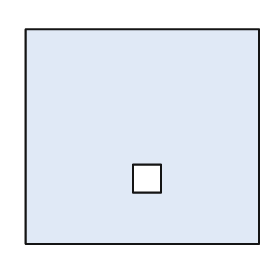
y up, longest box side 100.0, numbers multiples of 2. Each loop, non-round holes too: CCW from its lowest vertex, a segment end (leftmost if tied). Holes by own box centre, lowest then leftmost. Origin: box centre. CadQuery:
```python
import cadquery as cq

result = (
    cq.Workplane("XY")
    .moveTo(-50.0, -46.0)
    .lineTo(50.0, -46.0)
    .lineTo(50.0, 46.0)
    .lineTo(-50.0, 46.0)
    .close()
    .moveTo(-4.0, -24.0)
    .lineTo(8.0, -24.0)
    .lineTo(8.0, -12.0)
    .lineTo(-4.0, -12.0)
    .close()
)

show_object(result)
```